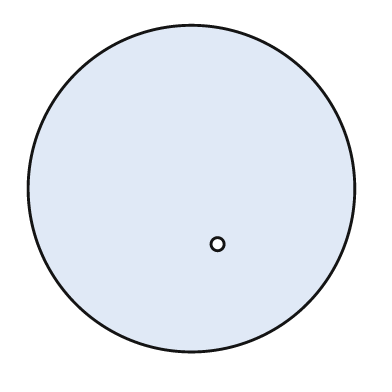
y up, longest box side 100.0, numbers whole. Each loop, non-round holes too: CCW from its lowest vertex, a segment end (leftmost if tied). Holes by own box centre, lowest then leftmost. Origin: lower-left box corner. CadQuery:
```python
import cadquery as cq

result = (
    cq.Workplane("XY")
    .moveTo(50.0, 50.0)
    .circle(50.0)
    .moveTo(58.0, 33.0)
    .circle(2.0)
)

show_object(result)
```